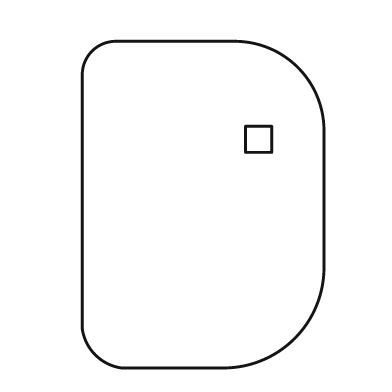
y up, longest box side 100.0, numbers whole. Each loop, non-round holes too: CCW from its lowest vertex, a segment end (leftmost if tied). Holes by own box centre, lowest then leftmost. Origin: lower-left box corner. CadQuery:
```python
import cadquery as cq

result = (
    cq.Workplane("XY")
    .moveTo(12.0, 0.0)
    .lineTo(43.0, 0.0)
    .threePointArc((65.0, 9.0), (74.0, 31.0))
    .lineTo(74.0, 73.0)
    .threePointArc((66.0, 92.0), (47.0, 100.0))
    .lineTo(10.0, 100.0)
    .threePointArc((3.0, 97.0), (0.0, 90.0))
    .lineTo(0.0, 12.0)
    .threePointArc((4.0, 4.0), (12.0, 0.0))
    .close()
    .moveTo(50.0, 66.0)
    .lineTo(58.0, 66.0)
    .lineTo(58.0, 74.0)
    .lineTo(50.0, 74.0)
    .close()
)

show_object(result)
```